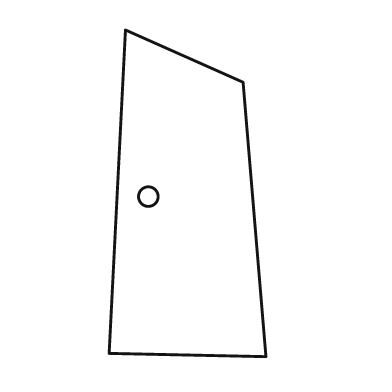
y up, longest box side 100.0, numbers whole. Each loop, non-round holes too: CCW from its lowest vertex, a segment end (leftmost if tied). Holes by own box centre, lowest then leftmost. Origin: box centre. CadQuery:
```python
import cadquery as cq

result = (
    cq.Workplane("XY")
    .moveTo(24.0, -50.0)
    .lineTo(17.0, 34.0)
    .lineTo(-19.0, 50.0)
    .lineTo(-24.0, -49.0)
    .close()
    .moveTo(-12.0, -1.0)
    .circle(3.0)
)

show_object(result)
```